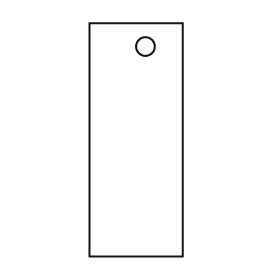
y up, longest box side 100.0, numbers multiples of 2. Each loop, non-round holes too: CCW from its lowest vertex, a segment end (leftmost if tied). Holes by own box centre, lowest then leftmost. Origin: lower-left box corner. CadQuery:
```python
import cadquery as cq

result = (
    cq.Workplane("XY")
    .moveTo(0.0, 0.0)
    .lineTo(40.0, 0.0)
    .lineTo(40.0, 100.0)
    .lineTo(0.0, 100.0)
    .close()
    .moveTo(24.0, 90.0)
    .circle(4.0)
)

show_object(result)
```